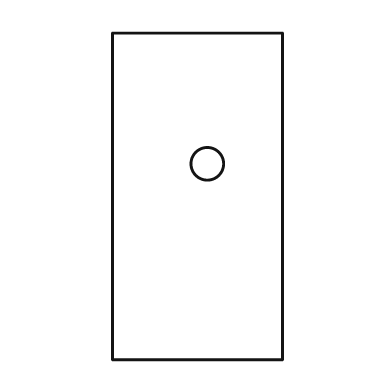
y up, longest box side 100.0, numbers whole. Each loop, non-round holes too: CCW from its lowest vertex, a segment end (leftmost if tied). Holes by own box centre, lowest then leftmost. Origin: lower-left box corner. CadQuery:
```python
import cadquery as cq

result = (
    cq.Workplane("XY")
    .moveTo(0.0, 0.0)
    .lineTo(52.0, 0.0)
    .lineTo(52.0, 100.0)
    .lineTo(0.0, 100.0)
    .close()
    .moveTo(29.0, 60.0)
    .circle(5.0)
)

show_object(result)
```